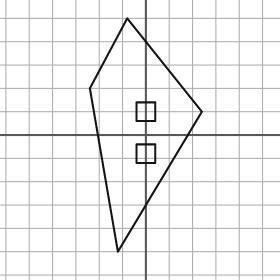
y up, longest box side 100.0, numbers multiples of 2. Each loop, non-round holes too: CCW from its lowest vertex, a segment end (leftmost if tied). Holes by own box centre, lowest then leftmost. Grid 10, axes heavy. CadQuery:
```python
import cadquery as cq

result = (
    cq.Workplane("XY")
    .moveTo(-12.0, -50.0)
    .lineTo(24.0, 10.0)
    .lineTo(-8.0, 50.0)
    .lineTo(-24.0, 20.0)
    .close()
    .moveTo(-4.0, -12.0)
    .lineTo(4.0, -12.0)
    .lineTo(4.0, -4.0)
    .lineTo(-4.0, -4.0)
    .close()
    .moveTo(-4.0, 6.0)
    .lineTo(4.0, 6.0)
    .lineTo(4.0, 14.0)
    .lineTo(-4.0, 14.0)
    .close()
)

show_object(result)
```